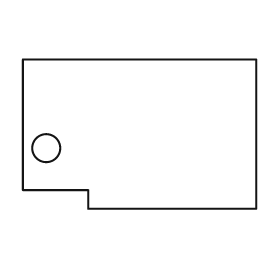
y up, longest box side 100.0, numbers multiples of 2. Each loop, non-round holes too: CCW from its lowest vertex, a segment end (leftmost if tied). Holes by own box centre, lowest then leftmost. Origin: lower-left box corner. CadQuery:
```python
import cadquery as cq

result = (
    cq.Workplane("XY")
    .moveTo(28.0, 0.0)
    .lineTo(100.0, 0.0)
    .lineTo(100.0, 64.0)
    .lineTo(0.0, 64.0)
    .lineTo(0.0, 8.0)
    .lineTo(28.0, 8.0)
    .close()
    .moveTo(10.0, 26.0)
    .circle(6.0)
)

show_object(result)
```